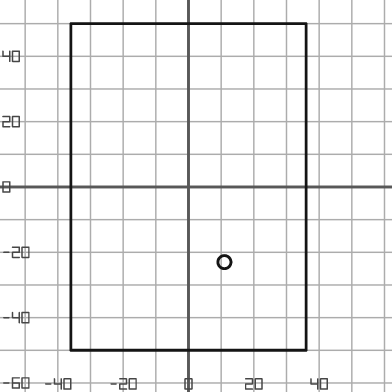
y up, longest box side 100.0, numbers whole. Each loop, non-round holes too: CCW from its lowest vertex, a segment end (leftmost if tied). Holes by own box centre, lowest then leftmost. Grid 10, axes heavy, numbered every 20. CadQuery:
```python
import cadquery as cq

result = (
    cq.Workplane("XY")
    .moveTo(-36.0, -50.0)
    .lineTo(36.0, -50.0)
    .lineTo(36.0, 50.0)
    .lineTo(-36.0, 50.0)
    .close()
    .moveTo(11.0, -23.0)
    .circle(2.0)
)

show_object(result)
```